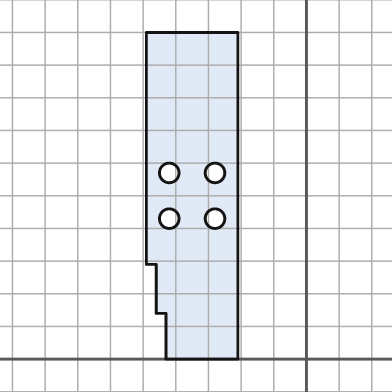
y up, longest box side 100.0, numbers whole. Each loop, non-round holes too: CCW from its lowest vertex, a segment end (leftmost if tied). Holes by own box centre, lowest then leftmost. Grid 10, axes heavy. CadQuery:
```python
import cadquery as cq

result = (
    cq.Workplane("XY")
    .moveTo(-43.0, 0.0)
    .lineTo(-21.0, 0.0)
    .lineTo(-21.0, 100.0)
    .lineTo(-49.0, 100.0)
    .lineTo(-49.0, 29.0)
    .lineTo(-46.0, 29.0)
    .lineTo(-46.0, 14.0)
    .lineTo(-43.0, 14.0)
    .close()
    .moveTo(-42.0, 43.0)
    .circle(3.0)
    .moveTo(-28.0, 43.0)
    .circle(3.0)
    .moveTo(-42.0, 57.0)
    .circle(3.0)
    .moveTo(-28.0, 57.0)
    .circle(3.0)
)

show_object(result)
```